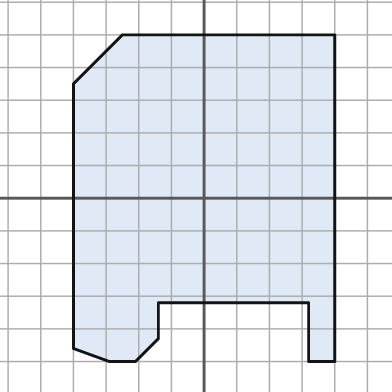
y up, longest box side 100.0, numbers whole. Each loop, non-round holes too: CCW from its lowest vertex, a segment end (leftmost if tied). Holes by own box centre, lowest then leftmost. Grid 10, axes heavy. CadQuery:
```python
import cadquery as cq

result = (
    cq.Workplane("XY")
    .moveTo(-29.0, -50.0)
    .lineTo(-21.0, -50.0)
    .lineTo(-14.0, -43.0)
    .lineTo(-14.0, -32.0)
    .lineTo(32.0, -32.0)
    .lineTo(32.0, -50.0)
    .lineTo(40.0, -50.0)
    .lineTo(40.0, 50.0)
    .lineTo(-25.0, 50.0)
    .lineTo(-40.0, 35.0)
    .lineTo(-40.0, -46.0)
    .close()
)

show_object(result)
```